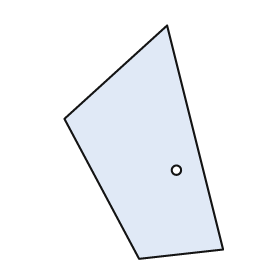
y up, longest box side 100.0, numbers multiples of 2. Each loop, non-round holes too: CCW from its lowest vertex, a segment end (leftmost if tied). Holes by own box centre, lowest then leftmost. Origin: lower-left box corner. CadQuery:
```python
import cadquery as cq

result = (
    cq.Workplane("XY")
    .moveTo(32.0, 0.0)
    .lineTo(68.0, 4.0)
    .lineTo(44.0, 100.0)
    .lineTo(0.0, 60.0)
    .close()
    .moveTo(48.0, 38.0)
    .circle(2.0)
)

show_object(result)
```